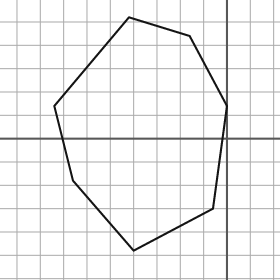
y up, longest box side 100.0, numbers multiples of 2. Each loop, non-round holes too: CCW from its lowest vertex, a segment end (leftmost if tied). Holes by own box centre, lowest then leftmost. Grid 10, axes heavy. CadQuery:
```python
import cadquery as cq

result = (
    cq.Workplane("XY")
    .moveTo(-40.0, -48.0)
    .lineTo(-6.0, -30.0)
    .lineTo(0.0, 14.0)
    .lineTo(-16.0, 44.0)
    .lineTo(-42.0, 52.0)
    .lineTo(-74.0, 14.0)
    .lineTo(-66.0, -18.0)
    .close()
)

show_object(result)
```